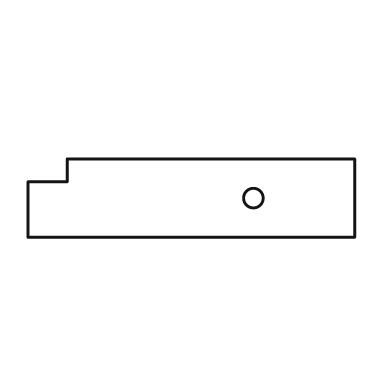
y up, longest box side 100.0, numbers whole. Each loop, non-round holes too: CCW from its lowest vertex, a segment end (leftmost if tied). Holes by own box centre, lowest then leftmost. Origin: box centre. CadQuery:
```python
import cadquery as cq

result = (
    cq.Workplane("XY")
    .moveTo(-50.0, -12.0)
    .lineTo(50.0, -12.0)
    .lineTo(50.0, 12.0)
    .lineTo(-38.0, 12.0)
    .lineTo(-38.0, 5.0)
    .lineTo(-50.0, 5.0)
    .close()
    .moveTo(19.0, 0.0)
    .circle(3.0)
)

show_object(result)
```